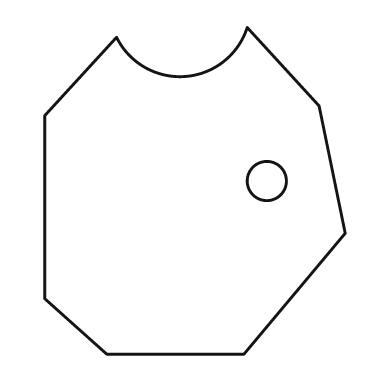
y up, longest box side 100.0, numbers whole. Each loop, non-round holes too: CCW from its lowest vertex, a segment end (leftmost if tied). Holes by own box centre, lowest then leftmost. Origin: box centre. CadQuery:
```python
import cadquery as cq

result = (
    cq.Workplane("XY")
    .moveTo(-27.0, -50.0)
    .lineTo(15.0, -50.0)
    .lineTo(46.0, -13.0)
    .lineTo(38.0, 26.0)
    .lineTo(16.0, 50.0)
    .threePointArc((-3.0, 35.0), (-24.0, 47.0))
    .lineTo(-46.0, 23.0)
    .lineTo(-46.0, -33.0)
    .close()
    .moveTo(22.0, 3.0)
    .circle(6.0)
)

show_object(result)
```